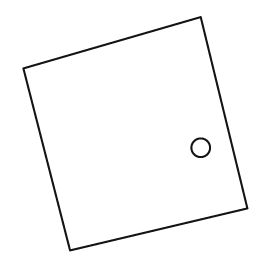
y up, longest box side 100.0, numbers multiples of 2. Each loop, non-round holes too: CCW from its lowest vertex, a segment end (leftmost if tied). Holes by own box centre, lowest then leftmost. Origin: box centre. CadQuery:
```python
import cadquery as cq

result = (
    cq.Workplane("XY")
    .moveTo(-28.0, -50.0)
    .lineTo(48.0, -32.0)
    .lineTo(28.0, 50.0)
    .lineTo(-48.0, 28.0)
    .close()
    .moveTo(28.0, -6.0)
    .circle(4.0)
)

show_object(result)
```